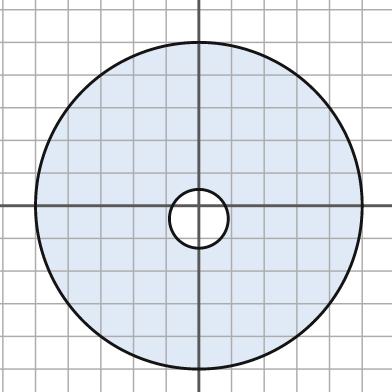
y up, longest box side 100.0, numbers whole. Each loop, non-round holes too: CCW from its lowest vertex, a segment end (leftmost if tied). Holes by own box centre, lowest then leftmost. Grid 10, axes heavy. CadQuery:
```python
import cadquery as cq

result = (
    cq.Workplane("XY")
    .moveTo(0.0, 0.0)
    .circle(50.0)
    .moveTo(0.0, -4.0)
    .circle(9.0)
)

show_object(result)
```